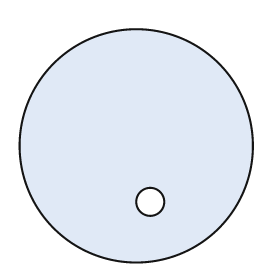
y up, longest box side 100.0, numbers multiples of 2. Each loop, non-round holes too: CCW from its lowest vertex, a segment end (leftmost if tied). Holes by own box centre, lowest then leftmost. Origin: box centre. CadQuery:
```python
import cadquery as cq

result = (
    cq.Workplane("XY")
    .moveTo(0.0, 0.0)
    .circle(50.0)
    .moveTo(6.0, -24.0)
    .circle(6.0)
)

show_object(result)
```